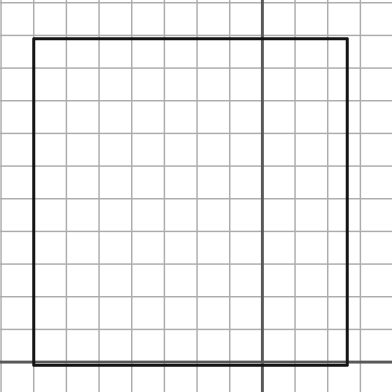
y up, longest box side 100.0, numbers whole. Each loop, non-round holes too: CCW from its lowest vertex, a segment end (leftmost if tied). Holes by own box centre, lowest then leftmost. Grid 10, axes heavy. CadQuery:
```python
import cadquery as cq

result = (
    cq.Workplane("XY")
    .moveTo(-70.0, -1.0)
    .lineTo(26.0, -1.0)
    .lineTo(26.0, 99.0)
    .lineTo(-70.0, 99.0)
    .close()
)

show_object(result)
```